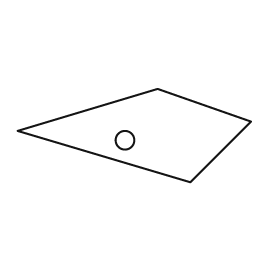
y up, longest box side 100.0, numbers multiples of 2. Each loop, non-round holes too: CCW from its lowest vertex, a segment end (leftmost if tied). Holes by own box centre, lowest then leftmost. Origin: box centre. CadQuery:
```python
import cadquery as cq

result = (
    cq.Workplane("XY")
    .moveTo(24.0, -20.0)
    .lineTo(50.0, 6.0)
    .lineTo(10.0, 20.0)
    .lineTo(-50.0, 2.0)
    .close()
    .moveTo(-4.0, -2.0)
    .circle(4.0)
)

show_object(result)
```